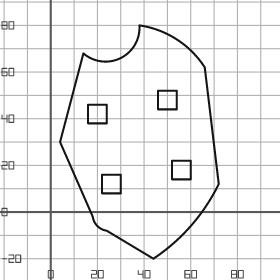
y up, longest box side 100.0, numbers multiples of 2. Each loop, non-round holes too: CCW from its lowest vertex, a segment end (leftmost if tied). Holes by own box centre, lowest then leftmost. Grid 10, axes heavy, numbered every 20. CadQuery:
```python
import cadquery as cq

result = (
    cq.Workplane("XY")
    .moveTo(44.0, -20.0)
    .threePointArc((60.0, -6.0), (72.0, 12.0))
    .lineTo(66.0, 62.0)
    .threePointArc((54.0, 74.0), (38.0, 80.0))
    .threePointArc((30.0, 66.0), (14.0, 68.0))
    .lineTo(4.0, 30.0)
    .lineTo(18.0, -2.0)
    .threePointArc((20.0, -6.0), (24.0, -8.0))
    .close()
    .moveTo(22.0, 8.0)
    .lineTo(30.0, 8.0)
    .lineTo(30.0, 16.0)
    .lineTo(22.0, 16.0)
    .close()
    .moveTo(52.0, 14.0)
    .lineTo(60.0, 14.0)
    .lineTo(60.0, 22.0)
    .lineTo(52.0, 22.0)
    .close()
    .moveTo(16.0, 38.0)
    .lineTo(24.0, 38.0)
    .lineTo(24.0, 46.0)
    .lineTo(16.0, 46.0)
    .close()
    .moveTo(46.0, 44.0)
    .lineTo(54.0, 44.0)
    .lineTo(54.0, 52.0)
    .lineTo(46.0, 52.0)
    .close()
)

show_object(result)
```